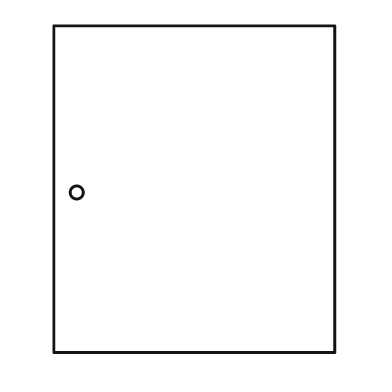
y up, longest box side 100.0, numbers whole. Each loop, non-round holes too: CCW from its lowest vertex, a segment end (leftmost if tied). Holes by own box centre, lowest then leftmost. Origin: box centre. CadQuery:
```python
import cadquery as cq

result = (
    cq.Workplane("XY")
    .moveTo(-43.0, -50.0)
    .lineTo(43.0, -50.0)
    .lineTo(43.0, 50.0)
    .lineTo(-43.0, 50.0)
    .close()
    .moveTo(-36.0, -1.0)
    .circle(2.0)
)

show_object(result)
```